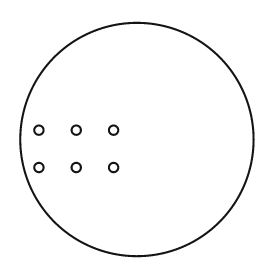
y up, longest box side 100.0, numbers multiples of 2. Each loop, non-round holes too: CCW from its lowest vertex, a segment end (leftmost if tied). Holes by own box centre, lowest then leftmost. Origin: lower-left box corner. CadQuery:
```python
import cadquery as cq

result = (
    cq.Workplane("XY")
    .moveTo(50.0, 50.0)
    .circle(50.0)
    .moveTo(8.0, 38.0)
    .circle(2.0)
    .moveTo(24.0, 38.0)
    .circle(2.0)
    .moveTo(40.0, 38.0)
    .circle(2.0)
    .moveTo(8.0, 54.0)
    .circle(2.0)
    .moveTo(24.0, 54.0)
    .circle(2.0)
    .moveTo(40.0, 54.0)
    .circle(2.0)
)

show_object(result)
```